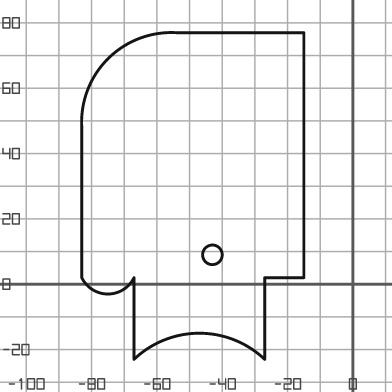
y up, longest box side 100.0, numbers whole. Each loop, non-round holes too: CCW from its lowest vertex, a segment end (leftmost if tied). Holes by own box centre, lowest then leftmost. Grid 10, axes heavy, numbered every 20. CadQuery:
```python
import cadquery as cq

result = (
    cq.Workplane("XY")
    .moveTo(-67.0, -23.0)
    .threePointArc((-47.0, -15.0), (-27.0, -23.0))
    .lineTo(-27.0, 2.0)
    .lineTo(-15.0, 2.0)
    .lineTo(-15.0, 77.0)
    .lineTo(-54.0, 77.0)
    .threePointArc((-75.0, 69.0), (-83.0, 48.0))
    .lineTo(-83.0, 2.0)
    .threePointArc((-75.0, -3.0), (-67.0, 2.0))
    .close()
    .moveTo(-43.0, 9.0)
    .circle(3.0)
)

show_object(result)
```